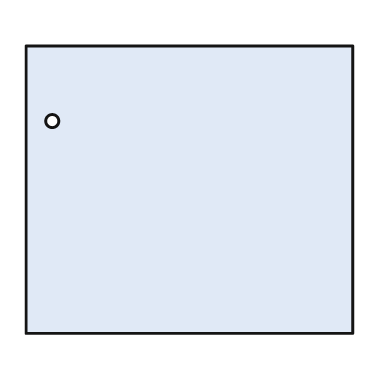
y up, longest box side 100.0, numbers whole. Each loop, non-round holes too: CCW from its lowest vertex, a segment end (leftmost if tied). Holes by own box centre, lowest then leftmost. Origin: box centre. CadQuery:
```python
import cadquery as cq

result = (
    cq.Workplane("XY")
    .moveTo(-50.0, -44.0)
    .lineTo(50.0, -44.0)
    .lineTo(50.0, 44.0)
    .lineTo(-50.0, 44.0)
    .close()
    .moveTo(-42.0, 21.0)
    .circle(2.0)
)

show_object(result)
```